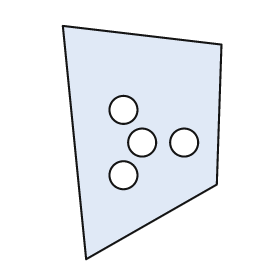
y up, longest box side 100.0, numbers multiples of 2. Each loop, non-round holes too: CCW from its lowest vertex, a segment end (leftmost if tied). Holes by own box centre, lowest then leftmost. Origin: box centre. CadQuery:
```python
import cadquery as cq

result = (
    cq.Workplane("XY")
    .moveTo(-24.0, -50.0)
    .lineTo(32.0, -18.0)
    .lineTo(34.0, 42.0)
    .lineTo(-34.0, 50.0)
    .close()
    .moveTo(-8.0, -14.0)
    .circle(6.0)
    .moveTo(0.0, 0.0)
    .circle(6.0)
    .moveTo(18.0, 0.0)
    .circle(6.0)
    .moveTo(-8.0, 14.0)
    .circle(6.0)
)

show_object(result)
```